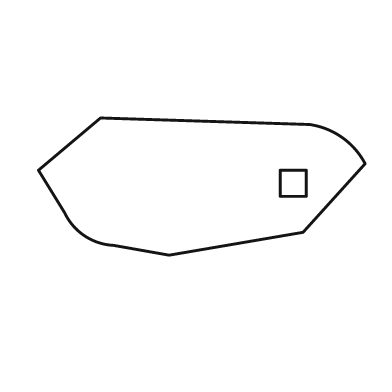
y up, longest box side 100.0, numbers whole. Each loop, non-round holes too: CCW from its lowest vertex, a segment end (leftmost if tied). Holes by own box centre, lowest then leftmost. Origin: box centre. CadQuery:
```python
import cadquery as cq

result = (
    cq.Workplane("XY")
    .moveTo(-10.0, -21.0)
    .lineTo(31.0, -14.0)
    .lineTo(50.0, 7.0)
    .threePointArc((43.0, 15.0), (33.0, 19.0))
    .lineTo(-31.0, 21.0)
    .lineTo(-50.0, 5.0)
    .lineTo(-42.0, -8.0)
    .threePointArc((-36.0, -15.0), (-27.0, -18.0))
    .close()
    .moveTo(24.0, -3.0)
    .lineTo(32.0, -3.0)
    .lineTo(32.0, 5.0)
    .lineTo(24.0, 5.0)
    .close()
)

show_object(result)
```